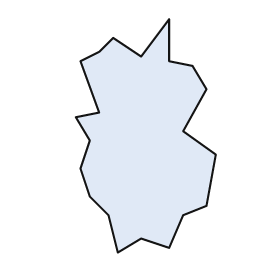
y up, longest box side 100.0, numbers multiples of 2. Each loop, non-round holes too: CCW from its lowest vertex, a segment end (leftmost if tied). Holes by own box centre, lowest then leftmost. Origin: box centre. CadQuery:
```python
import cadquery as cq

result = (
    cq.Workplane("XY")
    .moveTo(-12.0, -50.0)
    .lineTo(-2.0, -44.0)
    .lineTo(10.0, -48.0)
    .lineTo(16.0, -34.0)
    .lineTo(26.0, -30.0)
    .lineTo(30.0, -8.0)
    .lineTo(16.0, 2.0)
    .lineTo(26.0, 20.0)
    .lineTo(20.0, 30.0)
    .lineTo(10.0, 32.0)
    .lineTo(10.0, 50.0)
    .lineTo(-2.0, 34.0)
    .lineTo(-14.0, 42.0)
    .lineTo(-20.0, 36.0)
    .lineTo(-28.0, 32.0)
    .lineTo(-20.0, 10.0)
    .lineTo(-30.0, 8.0)
    .lineTo(-24.0, -2.0)
    .lineTo(-28.0, -14.0)
    .lineTo(-24.0, -26.0)
    .lineTo(-16.0, -34.0)
    .close()
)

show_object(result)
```